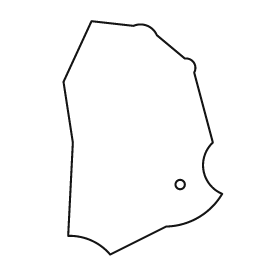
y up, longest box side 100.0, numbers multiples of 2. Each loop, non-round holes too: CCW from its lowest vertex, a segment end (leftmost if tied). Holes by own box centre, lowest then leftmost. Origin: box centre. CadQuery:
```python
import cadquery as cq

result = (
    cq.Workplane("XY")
    .moveTo(-14.0, -50.0)
    .lineTo(10.0, -38.0)
    .threePointArc((24.0, -34.0), (34.0, -24.0))
    .threePointArc((26.0, -14.0), (30.0, -2.0))
    .lineTo(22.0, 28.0)
    .threePointArc((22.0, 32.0), (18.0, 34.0))
    .lineTo(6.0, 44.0)
    .threePointArc((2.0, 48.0), (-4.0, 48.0))
    .lineTo(-22.0, 50.0)
    .lineTo(-34.0, 24.0)
    .lineTo(-30.0, -2.0)
    .lineTo(-32.0, -42.0)
    .threePointArc((-22.0, -44.0), (-14.0, -50.0))
    .close()
    .moveTo(16.0, -20.0)
    .circle(2.0)
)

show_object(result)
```